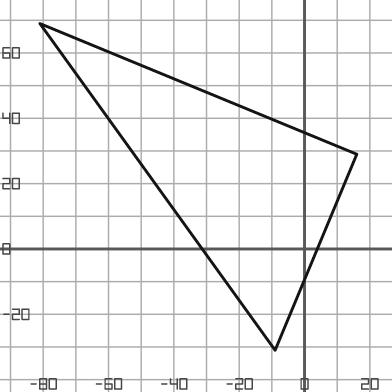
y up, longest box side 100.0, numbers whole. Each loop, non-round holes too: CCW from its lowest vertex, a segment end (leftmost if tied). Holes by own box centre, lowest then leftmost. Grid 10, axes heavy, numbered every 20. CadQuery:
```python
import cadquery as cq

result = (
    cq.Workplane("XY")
    .moveTo(-9.0, -31.0)
    .lineTo(16.0, 29.0)
    .lineTo(-81.0, 69.0)
    .close()
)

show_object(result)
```